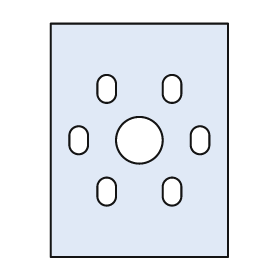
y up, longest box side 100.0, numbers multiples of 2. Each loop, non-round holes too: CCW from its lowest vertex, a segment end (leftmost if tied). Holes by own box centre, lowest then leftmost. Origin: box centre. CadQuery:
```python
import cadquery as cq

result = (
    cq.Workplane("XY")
    .moveTo(-38.0, -50.0)
    .lineTo(38.0, -50.0)
    .lineTo(38.0, 50.0)
    .lineTo(-38.0, 50.0)
    .close()
    .moveTo(-18.0, -24.0)
    .threePointArc((-14.0, -28.0), (-10.0, -24.0))
    .lineTo(-10.0, -20.0)
    .threePointArc((-14.0, -16.0), (-18.0, -20.0))
    .close()
    .moveTo(10.0, -24.0)
    .threePointArc((14.0, -28.0), (18.0, -24.0))
    .lineTo(18.0, -20.0)
    .threePointArc((14.0, -16.0), (10.0, -20.0))
    .close()
    .moveTo(-30.0, -2.0)
    .threePointArc((-26.0, -6.0), (-22.0, -2.0))
    .lineTo(-22.0, 2.0)
    .threePointArc((-26.0, 6.0), (-30.0, 2.0))
    .close()
    .moveTo(0.0, 0.0)
    .circle(10.0)
    .moveTo(22.0, -2.0)
    .threePointArc((26.0, -6.0), (30.0, -2.0))
    .lineTo(30.0, 2.0)
    .threePointArc((26.0, 6.0), (22.0, 2.0))
    .close()
    .moveTo(-18.0, 20.0)
    .threePointArc((-14.0, 16.0), (-10.0, 20.0))
    .lineTo(-10.0, 24.0)
    .threePointArc((-14.0, 28.0), (-18.0, 24.0))
    .close()
    .moveTo(10.0, 20.0)
    .threePointArc((14.0, 16.0), (18.0, 20.0))
    .lineTo(18.0, 24.0)
    .threePointArc((14.0, 28.0), (10.0, 24.0))
    .close()
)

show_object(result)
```